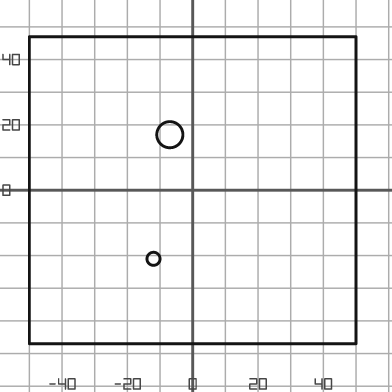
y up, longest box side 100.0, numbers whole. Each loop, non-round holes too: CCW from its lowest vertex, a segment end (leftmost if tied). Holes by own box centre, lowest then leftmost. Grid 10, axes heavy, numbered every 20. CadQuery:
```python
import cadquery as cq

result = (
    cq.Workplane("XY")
    .moveTo(-50.0, -47.0)
    .lineTo(50.0, -47.0)
    .lineTo(50.0, 47.0)
    .lineTo(-50.0, 47.0)
    .close()
    .moveTo(-12.0, -21.0)
    .circle(2.0)
    .moveTo(-7.0, 17.0)
    .circle(4.0)
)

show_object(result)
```